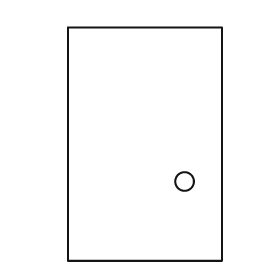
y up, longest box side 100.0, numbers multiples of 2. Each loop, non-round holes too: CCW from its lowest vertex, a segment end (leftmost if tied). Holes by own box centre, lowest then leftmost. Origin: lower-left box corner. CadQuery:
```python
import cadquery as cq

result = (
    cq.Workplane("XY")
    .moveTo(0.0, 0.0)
    .lineTo(66.0, 0.0)
    .lineTo(66.0, 100.0)
    .lineTo(0.0, 100.0)
    .close()
    .moveTo(50.0, 34.0)
    .circle(4.0)
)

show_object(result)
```